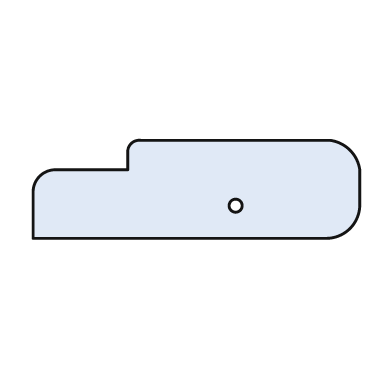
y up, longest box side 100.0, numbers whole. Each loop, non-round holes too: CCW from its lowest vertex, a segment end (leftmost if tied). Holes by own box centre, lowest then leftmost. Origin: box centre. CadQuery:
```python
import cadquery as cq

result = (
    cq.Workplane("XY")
    .moveTo(-50.0, -15.0)
    .lineTo(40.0, -15.0)
    .threePointArc((47.0, -12.0), (50.0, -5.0))
    .lineTo(50.0, 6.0)
    .threePointArc((47.0, 12.0), (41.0, 15.0))
    .lineTo(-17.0, 15.0)
    .threePointArc((-20.0, 14.0), (-21.0, 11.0))
    .lineTo(-21.0, 6.0)
    .lineTo(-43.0, 6.0)
    .threePointArc((-48.0, 4.0), (-50.0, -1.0))
    .close()
    .moveTo(12.0, -5.0)
    .circle(2.0)
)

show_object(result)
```